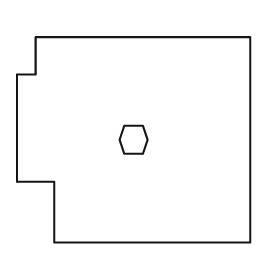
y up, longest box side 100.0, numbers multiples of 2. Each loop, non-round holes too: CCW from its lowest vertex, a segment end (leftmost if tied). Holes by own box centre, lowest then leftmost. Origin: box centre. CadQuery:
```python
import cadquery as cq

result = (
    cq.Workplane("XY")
    .moveTo(-34.0, -44.0)
    .lineTo(50.0, -44.0)
    .lineTo(50.0, 44.0)
    .lineTo(-42.0, 44.0)
    .lineTo(-42.0, 28.0)
    .lineTo(-50.0, 28.0)
    .lineTo(-50.0, -18.0)
    .lineTo(-34.0, -18.0)
    .close()
    .moveTo(-4.0, -6.0)
    .lineTo(4.0, -6.0)
    .lineTo(6.0, 0.0)
    .lineTo(4.0, 6.0)
    .lineTo(-4.0, 6.0)
    .lineTo(-6.0, 0.0)
    .close()
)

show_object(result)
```